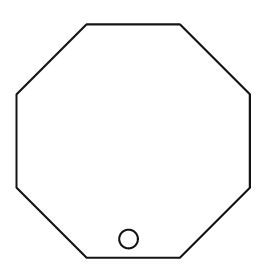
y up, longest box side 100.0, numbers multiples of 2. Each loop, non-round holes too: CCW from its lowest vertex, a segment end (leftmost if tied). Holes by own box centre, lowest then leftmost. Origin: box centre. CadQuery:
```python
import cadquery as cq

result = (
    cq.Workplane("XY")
    .moveTo(-20.0, -50.0)
    .lineTo(20.0, -50.0)
    .lineTo(50.0, -20.0)
    .lineTo(50.0, 20.0)
    .lineTo(20.0, 50.0)
    .lineTo(-20.0, 50.0)
    .lineTo(-50.0, 20.0)
    .lineTo(-50.0, -20.0)
    .close()
    .moveTo(-2.0, -42.0)
    .circle(4.0)
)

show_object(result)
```